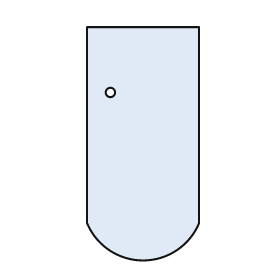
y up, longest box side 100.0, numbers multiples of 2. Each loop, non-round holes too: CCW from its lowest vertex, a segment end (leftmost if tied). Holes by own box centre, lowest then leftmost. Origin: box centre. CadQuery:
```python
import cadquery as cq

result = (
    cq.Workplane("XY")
    .moveTo(-24.0, -34.0)
    .threePointArc((0.0, -50.0), (24.0, -34.0))
    .lineTo(24.0, 50.0)
    .lineTo(-24.0, 50.0)
    .close()
    .moveTo(-14.0, 22.0)
    .circle(2.0)
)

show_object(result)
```